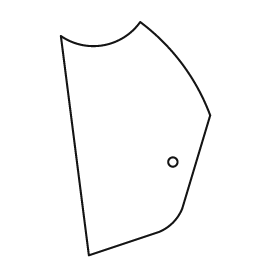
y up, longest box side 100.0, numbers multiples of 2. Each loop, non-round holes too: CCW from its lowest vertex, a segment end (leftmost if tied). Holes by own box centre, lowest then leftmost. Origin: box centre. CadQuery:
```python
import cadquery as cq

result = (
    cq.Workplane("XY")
    .moveTo(-20.0, -50.0)
    .lineTo(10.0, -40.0)
    .threePointArc((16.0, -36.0), (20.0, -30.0))
    .lineTo(32.0, 10.0)
    .threePointArc((20.0, 32.0), (2.0, 50.0))
    .threePointArc((-14.0, 40.0), (-32.0, 44.0))
    .close()
    .moveTo(16.0, -10.0)
    .circle(2.0)
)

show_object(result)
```